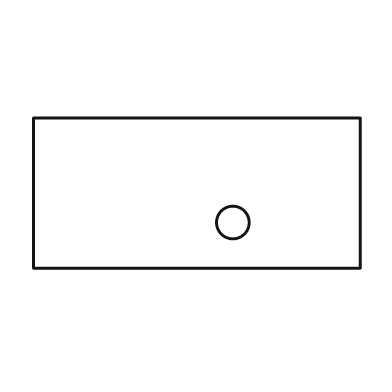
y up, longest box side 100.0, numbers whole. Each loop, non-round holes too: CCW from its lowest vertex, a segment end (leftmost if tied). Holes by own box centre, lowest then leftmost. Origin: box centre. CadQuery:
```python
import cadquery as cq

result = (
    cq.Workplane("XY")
    .moveTo(-50.0, -23.0)
    .lineTo(50.0, -23.0)
    .lineTo(50.0, 23.0)
    .lineTo(-50.0, 23.0)
    .close()
    .moveTo(11.0, -9.0)
    .circle(5.0)
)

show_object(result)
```